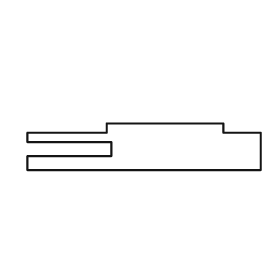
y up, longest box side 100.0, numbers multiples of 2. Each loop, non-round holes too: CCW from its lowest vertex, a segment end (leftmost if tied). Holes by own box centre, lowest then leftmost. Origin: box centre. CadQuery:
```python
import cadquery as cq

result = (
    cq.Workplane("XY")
    .moveTo(-50.0, -10.0)
    .lineTo(50.0, -10.0)
    .lineTo(50.0, 6.0)
    .lineTo(34.0, 6.0)
    .lineTo(34.0, 10.0)
    .lineTo(-16.0, 10.0)
    .lineTo(-16.0, 6.0)
    .lineTo(-50.0, 6.0)
    .lineTo(-50.0, 2.0)
    .lineTo(-14.0, 2.0)
    .lineTo(-14.0, -4.0)
    .lineTo(-50.0, -4.0)
    .close()
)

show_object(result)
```